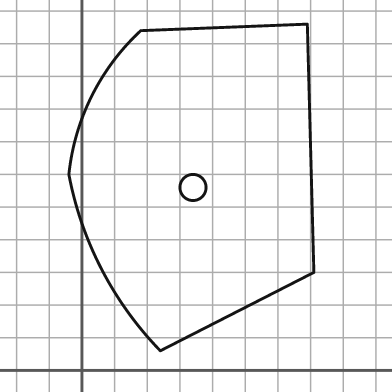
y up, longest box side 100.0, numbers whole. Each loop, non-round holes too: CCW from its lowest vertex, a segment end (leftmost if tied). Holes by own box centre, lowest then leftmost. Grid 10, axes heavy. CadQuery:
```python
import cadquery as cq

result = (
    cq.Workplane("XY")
    .moveTo(24.0, 6.0)
    .lineTo(71.0, 30.0)
    .lineTo(69.0, 106.0)
    .lineTo(18.0, 104.0)
    .threePointArc((3.0, 84.0), (-4.0, 60.0))
    .threePointArc((6.0, 31.0), (24.0, 6.0))
    .close()
    .moveTo(34.0, 56.0)
    .circle(4.0)
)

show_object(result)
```